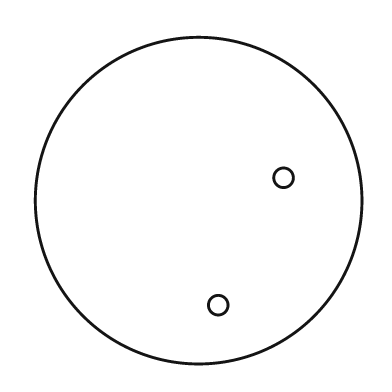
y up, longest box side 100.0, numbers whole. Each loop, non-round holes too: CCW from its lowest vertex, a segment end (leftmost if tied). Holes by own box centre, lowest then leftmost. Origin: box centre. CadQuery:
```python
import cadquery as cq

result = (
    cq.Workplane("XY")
    .moveTo(0.0, 0.0)
    .circle(50.0)
    .moveTo(6.0, -32.0)
    .circle(3.0)
    .moveTo(26.0, 7.0)
    .circle(3.0)
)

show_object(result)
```